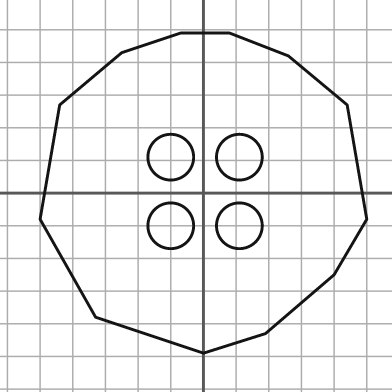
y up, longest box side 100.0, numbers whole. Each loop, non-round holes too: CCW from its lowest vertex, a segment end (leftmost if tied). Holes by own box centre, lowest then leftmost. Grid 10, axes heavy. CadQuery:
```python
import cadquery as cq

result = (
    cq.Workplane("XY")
    .moveTo(0.0, -49.0)
    .lineTo(19.0, -43.0)
    .lineTo(40.0, -25.0)
    .lineTo(50.0, -8.0)
    .lineTo(44.0, 27.0)
    .lineTo(26.0, 42.0)
    .lineTo(8.0, 49.0)
    .lineTo(-7.0, 49.0)
    .lineTo(-25.0, 43.0)
    .lineTo(-44.0, 27.0)
    .lineTo(-50.0, -8.0)
    .lineTo(-33.0, -38.0)
    .close()
    .moveTo(-10.0, -10.0)
    .circle(7.0)
    .moveTo(11.0, -10.0)
    .circle(7.0)
    .moveTo(-10.0, 11.0)
    .circle(7.0)
    .moveTo(11.0, 11.0)
    .circle(7.0)
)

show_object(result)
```